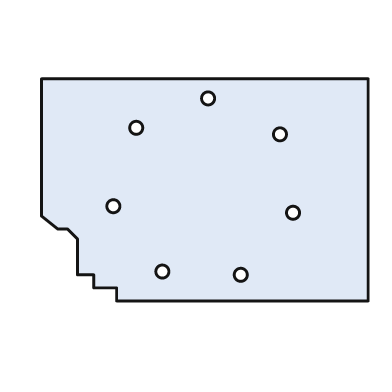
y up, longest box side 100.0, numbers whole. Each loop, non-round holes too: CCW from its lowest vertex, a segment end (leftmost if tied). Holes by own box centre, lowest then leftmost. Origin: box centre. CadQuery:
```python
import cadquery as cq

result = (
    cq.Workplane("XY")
    .moveTo(-27.0, -34.0)
    .lineTo(50.0, -34.0)
    .lineTo(50.0, 34.0)
    .lineTo(-50.0, 34.0)
    .lineTo(-50.0, -8.0)
    .lineTo(-45.0, -12.0)
    .lineTo(-42.0, -12.0)
    .lineTo(-39.0, -15.0)
    .lineTo(-39.0, -26.0)
    .lineTo(-34.0, -26.0)
    .lineTo(-34.0, -30.0)
    .lineTo(-27.0, -30.0)
    .close()
    .moveTo(11.0, -26.0)
    .circle(2.0)
    .moveTo(-13.0, -25.0)
    .circle(2.0)
    .moveTo(27.0, -7.0)
    .circle(2.0)
    .moveTo(-28.0, -5.0)
    .circle(2.0)
    .moveTo(23.0, 17.0)
    .circle(2.0)
    .moveTo(-21.0, 19.0)
    .circle(2.0)
    .moveTo(1.0, 28.0)
    .circle(2.0)
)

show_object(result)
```